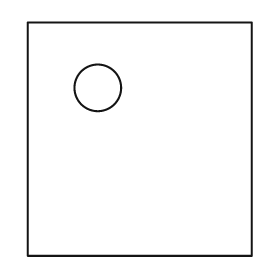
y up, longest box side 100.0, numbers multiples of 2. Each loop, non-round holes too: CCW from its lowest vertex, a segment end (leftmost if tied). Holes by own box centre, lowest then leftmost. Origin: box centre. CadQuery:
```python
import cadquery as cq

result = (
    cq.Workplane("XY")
    .moveTo(-48.0, -50.0)
    .lineTo(48.0, -50.0)
    .lineTo(48.0, 50.0)
    .lineTo(-48.0, 50.0)
    .close()
    .moveTo(-18.0, 22.0)
    .circle(10.0)
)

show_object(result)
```